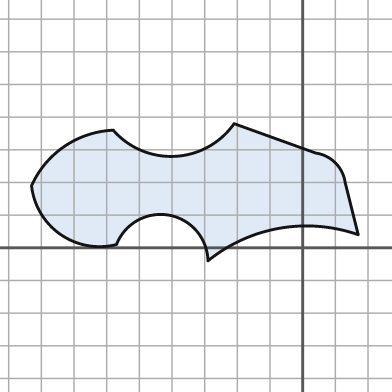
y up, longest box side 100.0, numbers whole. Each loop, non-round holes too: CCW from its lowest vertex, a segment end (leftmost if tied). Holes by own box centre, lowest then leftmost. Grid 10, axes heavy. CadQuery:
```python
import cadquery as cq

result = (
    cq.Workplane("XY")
    .moveTo(-29.0, -4.0)
    .threePointArc((-7.0, 6.0), (17.0, 4.0))
    .lineTo(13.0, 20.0)
    .threePointArc((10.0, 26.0), (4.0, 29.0))
    .lineTo(-21.0, 38.0)
    .threePointArc((-39.0, 28.0), (-58.0, 36.0))
    .threePointArc((-73.0, 31.0), (-83.0, 19.0))
    .threePointArc((-74.0, 4.0), (-57.0, 1.0))
    .threePointArc((-41.0, 10.0), (-29.0, -4.0))
    .close()
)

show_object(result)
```